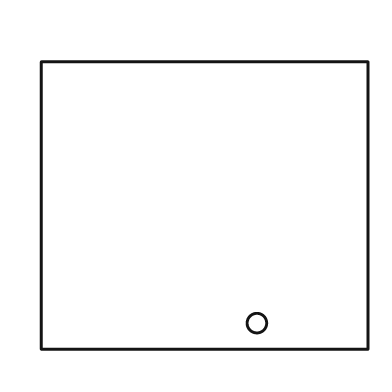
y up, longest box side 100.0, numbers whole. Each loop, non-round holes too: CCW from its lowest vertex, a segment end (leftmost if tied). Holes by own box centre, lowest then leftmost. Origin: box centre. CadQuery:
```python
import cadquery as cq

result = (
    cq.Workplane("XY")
    .moveTo(-50.0, -44.0)
    .lineTo(50.0, -44.0)
    .lineTo(50.0, 44.0)
    .lineTo(-50.0, 44.0)
    .close()
    .moveTo(16.0, -36.0)
    .circle(3.0)
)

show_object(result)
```